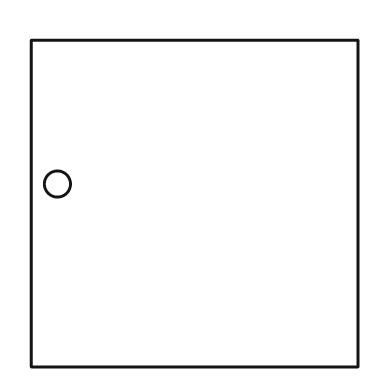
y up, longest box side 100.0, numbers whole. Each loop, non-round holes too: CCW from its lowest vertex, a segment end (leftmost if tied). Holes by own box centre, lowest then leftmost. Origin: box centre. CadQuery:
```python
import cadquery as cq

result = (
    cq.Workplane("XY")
    .moveTo(-50.0, -50.0)
    .lineTo(50.0, -50.0)
    .lineTo(50.0, 50.0)
    .lineTo(-50.0, 50.0)
    .close()
    .moveTo(-42.0, 6.0)
    .circle(4.0)
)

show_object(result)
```